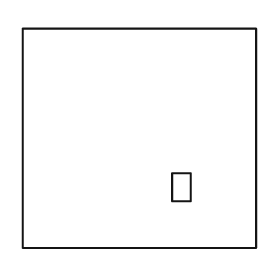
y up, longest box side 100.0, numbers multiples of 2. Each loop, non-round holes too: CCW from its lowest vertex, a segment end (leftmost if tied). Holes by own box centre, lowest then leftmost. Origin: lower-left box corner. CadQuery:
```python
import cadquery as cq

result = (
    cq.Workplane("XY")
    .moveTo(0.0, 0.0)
    .lineTo(100.0, 0.0)
    .lineTo(100.0, 94.0)
    .lineTo(0.0, 94.0)
    .close()
    .moveTo(64.0, 20.0)
    .lineTo(72.0, 20.0)
    .lineTo(72.0, 32.0)
    .lineTo(64.0, 32.0)
    .close()
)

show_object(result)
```